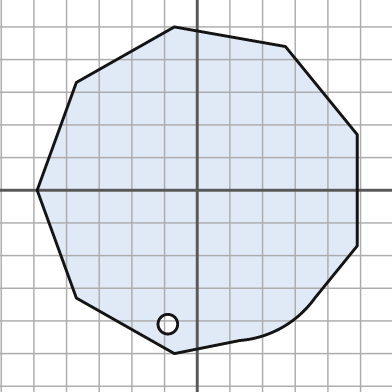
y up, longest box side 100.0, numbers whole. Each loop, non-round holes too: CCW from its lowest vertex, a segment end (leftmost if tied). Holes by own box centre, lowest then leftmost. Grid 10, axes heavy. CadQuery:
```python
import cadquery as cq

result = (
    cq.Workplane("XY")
    .moveTo(-7.0, -50.0)
    .lineTo(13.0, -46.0)
    .threePointArc((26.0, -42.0), (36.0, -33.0))
    .lineTo(49.0, -17.0)
    .lineTo(49.0, 17.0)
    .lineTo(27.0, 44.0)
    .lineTo(-7.0, 50.0)
    .lineTo(-37.0, 33.0)
    .lineTo(-49.0, 0.0)
    .lineTo(-37.0, -33.0)
    .close()
    .moveTo(-9.0, -41.0)
    .circle(3.0)
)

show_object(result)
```